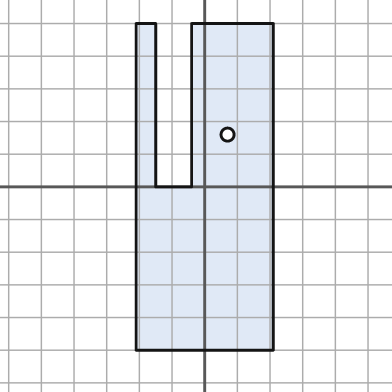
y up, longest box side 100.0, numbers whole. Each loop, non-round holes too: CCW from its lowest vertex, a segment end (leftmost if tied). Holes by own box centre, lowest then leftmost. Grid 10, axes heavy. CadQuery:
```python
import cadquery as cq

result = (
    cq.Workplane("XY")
    .moveTo(-21.0, -50.0)
    .lineTo(21.0, -50.0)
    .lineTo(21.0, 50.0)
    .lineTo(-4.0, 50.0)
    .lineTo(-4.0, 0.0)
    .lineTo(-15.0, 0.0)
    .lineTo(-15.0, 50.0)
    .lineTo(-21.0, 50.0)
    .close()
    .moveTo(7.0, 16.0)
    .circle(2.0)
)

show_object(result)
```